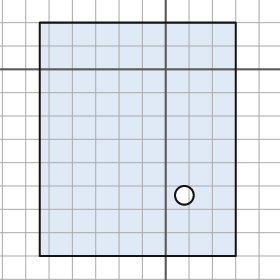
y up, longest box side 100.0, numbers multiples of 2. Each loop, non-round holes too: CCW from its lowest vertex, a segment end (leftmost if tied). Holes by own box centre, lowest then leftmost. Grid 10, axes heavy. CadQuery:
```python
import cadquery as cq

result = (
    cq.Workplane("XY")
    .moveTo(-54.0, -80.0)
    .lineTo(30.0, -80.0)
    .lineTo(30.0, 20.0)
    .lineTo(-54.0, 20.0)
    .close()
    .moveTo(8.0, -54.0)
    .circle(4.0)
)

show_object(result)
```